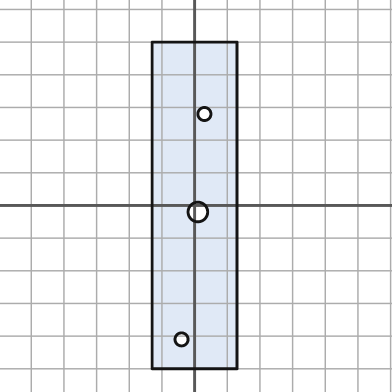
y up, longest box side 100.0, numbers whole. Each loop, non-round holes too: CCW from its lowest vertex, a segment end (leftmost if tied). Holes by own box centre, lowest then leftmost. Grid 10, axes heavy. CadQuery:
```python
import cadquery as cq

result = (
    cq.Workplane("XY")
    .moveTo(-13.0, -50.0)
    .lineTo(13.0, -50.0)
    .lineTo(13.0, 50.0)
    .lineTo(-13.0, 50.0)
    .close()
    .moveTo(-4.0, -41.0)
    .circle(2.0)
    .moveTo(1.0, -2.0)
    .circle(3.0)
    .moveTo(3.0, 28.0)
    .circle(2.0)
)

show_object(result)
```